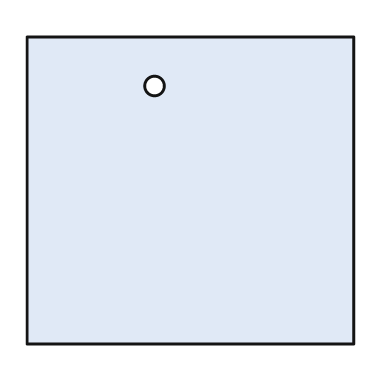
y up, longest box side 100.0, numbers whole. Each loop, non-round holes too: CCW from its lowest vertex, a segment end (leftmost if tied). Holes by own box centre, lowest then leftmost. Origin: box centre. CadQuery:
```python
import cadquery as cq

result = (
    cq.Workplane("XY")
    .moveTo(-50.0, -47.0)
    .lineTo(50.0, -47.0)
    .lineTo(50.0, 47.0)
    .lineTo(-50.0, 47.0)
    .close()
    .moveTo(-11.0, 32.0)
    .circle(3.0)
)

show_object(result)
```